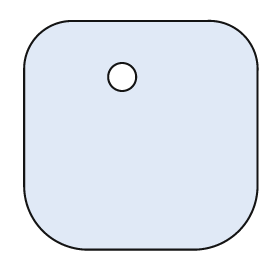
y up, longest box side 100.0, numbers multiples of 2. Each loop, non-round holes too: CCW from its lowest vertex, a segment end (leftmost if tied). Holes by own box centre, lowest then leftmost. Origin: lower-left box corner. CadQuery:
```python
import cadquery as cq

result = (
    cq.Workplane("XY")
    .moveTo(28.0, 0.0)
    .lineTo(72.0, 0.0)
    .threePointArc((92.0, 8.0), (100.0, 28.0))
    .lineTo(100.0, 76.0)
    .threePointArc((94.0, 92.0), (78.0, 98.0))
    .lineTo(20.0, 98.0)
    .threePointArc((6.0, 92.0), (0.0, 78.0))
    .lineTo(0.0, 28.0)
    .threePointArc((8.0, 8.0), (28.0, 0.0))
    .close()
    .moveTo(42.0, 74.0)
    .circle(6.0)
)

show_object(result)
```